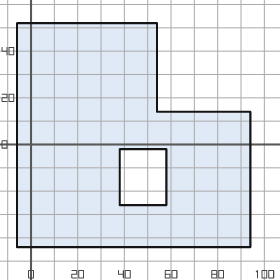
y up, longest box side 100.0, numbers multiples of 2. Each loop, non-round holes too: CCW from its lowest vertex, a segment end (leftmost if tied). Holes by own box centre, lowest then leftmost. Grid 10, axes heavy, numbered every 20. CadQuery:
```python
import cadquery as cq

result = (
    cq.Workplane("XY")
    .moveTo(-6.0, -44.0)
    .lineTo(94.0, -44.0)
    .lineTo(94.0, 14.0)
    .lineTo(54.0, 14.0)
    .lineTo(54.0, 52.0)
    .lineTo(-6.0, 52.0)
    .close()
    .moveTo(38.0, -26.0)
    .lineTo(58.0, -26.0)
    .lineTo(58.0, -2.0)
    .lineTo(38.0, -2.0)
    .close()
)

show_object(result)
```